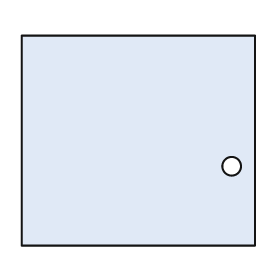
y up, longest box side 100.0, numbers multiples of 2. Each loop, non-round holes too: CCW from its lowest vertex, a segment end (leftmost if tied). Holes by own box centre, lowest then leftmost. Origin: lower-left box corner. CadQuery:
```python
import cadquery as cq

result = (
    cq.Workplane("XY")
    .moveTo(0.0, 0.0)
    .lineTo(100.0, 0.0)
    .lineTo(100.0, 90.0)
    .lineTo(0.0, 90.0)
    .close()
    .moveTo(90.0, 34.0)
    .circle(4.0)
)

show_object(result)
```